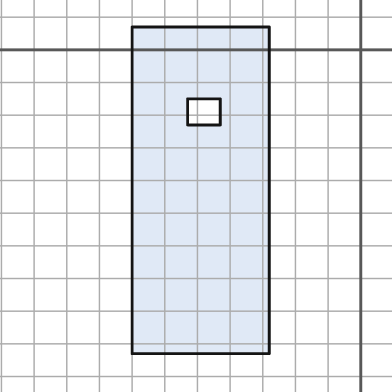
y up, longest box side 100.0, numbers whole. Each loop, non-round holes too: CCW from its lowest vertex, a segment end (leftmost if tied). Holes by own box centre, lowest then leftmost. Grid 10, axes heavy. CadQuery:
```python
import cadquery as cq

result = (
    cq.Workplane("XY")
    .moveTo(-70.0, -93.0)
    .lineTo(-28.0, -93.0)
    .lineTo(-28.0, 7.0)
    .lineTo(-70.0, 7.0)
    .close()
    .moveTo(-53.0, -23.0)
    .lineTo(-43.0, -23.0)
    .lineTo(-43.0, -15.0)
    .lineTo(-53.0, -15.0)
    .close()
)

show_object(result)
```